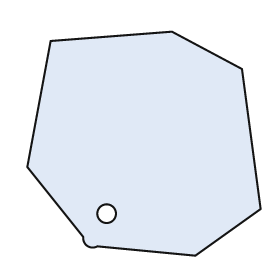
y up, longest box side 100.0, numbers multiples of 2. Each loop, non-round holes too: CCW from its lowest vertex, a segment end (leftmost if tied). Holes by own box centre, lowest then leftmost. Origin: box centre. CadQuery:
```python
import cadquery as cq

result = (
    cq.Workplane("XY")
    .moveTo(22.0, -48.0)
    .lineTo(50.0, -28.0)
    .lineTo(42.0, 32.0)
    .lineTo(12.0, 48.0)
    .lineTo(-40.0, 44.0)
    .lineTo(-50.0, -10.0)
    .lineTo(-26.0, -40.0)
    .threePointArc((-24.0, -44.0), (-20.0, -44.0))
    .close()
    .moveTo(-16.0, -30.0)
    .circle(4.0)
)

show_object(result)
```